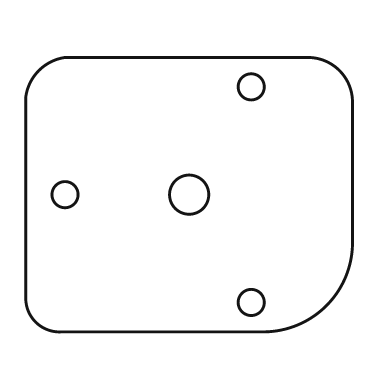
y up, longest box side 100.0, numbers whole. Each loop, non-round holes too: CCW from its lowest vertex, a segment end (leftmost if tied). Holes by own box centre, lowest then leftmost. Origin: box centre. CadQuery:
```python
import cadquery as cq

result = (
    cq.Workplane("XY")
    .moveTo(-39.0, -42.0)
    .lineTo(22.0, -42.0)
    .threePointArc((42.0, -34.0), (50.0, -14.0))
    .lineTo(50.0, 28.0)
    .threePointArc((46.0, 38.0), (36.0, 42.0))
    .lineTo(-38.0, 42.0)
    .threePointArc((-46.0, 38.0), (-50.0, 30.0))
    .lineTo(-50.0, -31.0)
    .threePointArc((-47.0, -39.0), (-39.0, -42.0))
    .close()
    .moveTo(19.0, -33.0)
    .circle(4.0)
    .moveTo(-38.0, 0.0)
    .circle(4.0)
    .moveTo(0.0, 0.0)
    .circle(6.0)
    .moveTo(19.0, 33.0)
    .circle(4.0)
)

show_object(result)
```